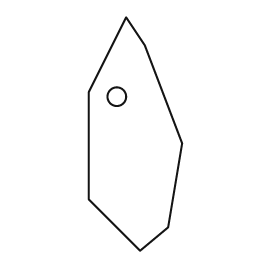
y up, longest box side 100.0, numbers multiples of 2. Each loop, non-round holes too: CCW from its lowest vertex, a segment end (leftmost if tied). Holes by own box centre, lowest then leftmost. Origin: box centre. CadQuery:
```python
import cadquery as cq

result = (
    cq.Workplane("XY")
    .moveTo(2.0, -50.0)
    .lineTo(14.0, -40.0)
    .lineTo(20.0, -4.0)
    .lineTo(4.0, 38.0)
    .lineTo(-4.0, 50.0)
    .lineTo(-20.0, 18.0)
    .lineTo(-20.0, -28.0)
    .close()
    .moveTo(-8.0, 16.0)
    .circle(4.0)
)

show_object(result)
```